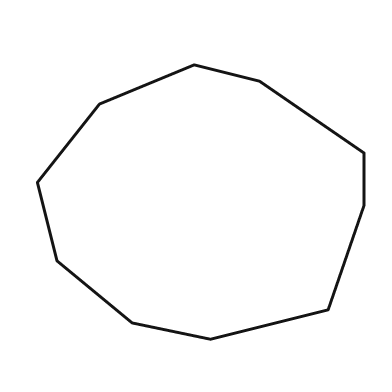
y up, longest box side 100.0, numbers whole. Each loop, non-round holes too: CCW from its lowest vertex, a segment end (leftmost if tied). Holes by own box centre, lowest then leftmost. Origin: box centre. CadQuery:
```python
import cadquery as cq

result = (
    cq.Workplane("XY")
    .moveTo(3.0, -42.0)
    .lineTo(39.0, -33.0)
    .lineTo(50.0, -1.0)
    .lineTo(50.0, 15.0)
    .lineTo(18.0, 37.0)
    .lineTo(-2.0, 42.0)
    .lineTo(-31.0, 30.0)
    .lineTo(-50.0, 6.0)
    .lineTo(-44.0, -18.0)
    .lineTo(-21.0, -37.0)
    .close()
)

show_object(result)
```